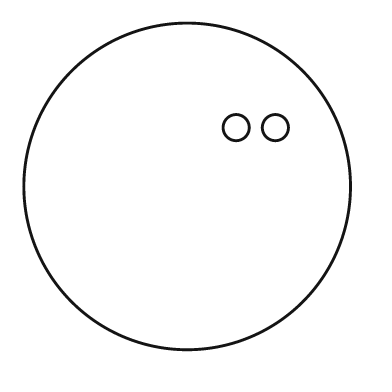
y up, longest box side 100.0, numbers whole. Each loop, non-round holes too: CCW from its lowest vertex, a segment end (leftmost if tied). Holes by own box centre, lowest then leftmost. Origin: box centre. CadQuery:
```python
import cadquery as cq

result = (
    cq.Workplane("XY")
    .moveTo(0.0, 0.0)
    .circle(50.0)
    .moveTo(15.0, 18.0)
    .circle(4.0)
    .moveTo(27.0, 18.0)
    .circle(4.0)
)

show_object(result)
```